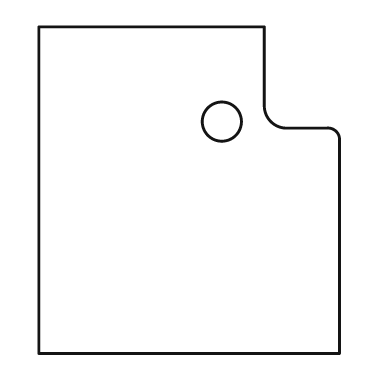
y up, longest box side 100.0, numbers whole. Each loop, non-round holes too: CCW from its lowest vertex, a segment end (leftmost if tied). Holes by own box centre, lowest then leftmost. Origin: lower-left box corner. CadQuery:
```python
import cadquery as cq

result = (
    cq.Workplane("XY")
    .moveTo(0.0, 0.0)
    .lineTo(92.0, 0.0)
    .lineTo(92.0, 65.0)
    .threePointArc((91.0, 68.0), (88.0, 69.0))
    .lineTo(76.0, 69.0)
    .threePointArc((71.0, 71.0), (69.0, 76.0))
    .lineTo(69.0, 100.0)
    .lineTo(0.0, 100.0)
    .close()
    .moveTo(56.0, 71.0)
    .circle(6.0)
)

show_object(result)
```